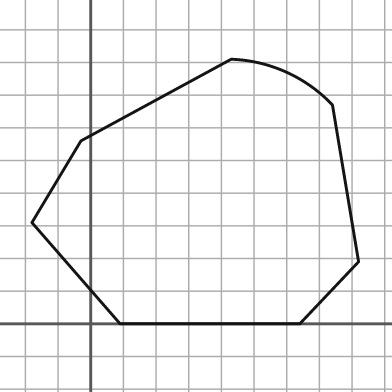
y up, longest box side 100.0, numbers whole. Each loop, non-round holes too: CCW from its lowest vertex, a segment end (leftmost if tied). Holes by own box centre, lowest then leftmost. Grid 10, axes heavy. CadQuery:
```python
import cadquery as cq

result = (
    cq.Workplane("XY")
    .moveTo(9.0, 0.0)
    .lineTo(64.0, 0.0)
    .lineTo(82.0, 19.0)
    .lineTo(74.0, 67.0)
    .threePointArc((60.0, 77.0), (43.0, 81.0))
    .lineTo(-3.0, 56.0)
    .lineTo(-18.0, 31.0)
    .close()
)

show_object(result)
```